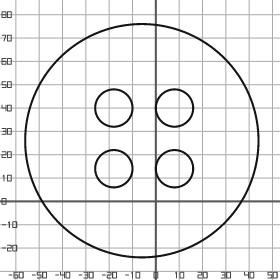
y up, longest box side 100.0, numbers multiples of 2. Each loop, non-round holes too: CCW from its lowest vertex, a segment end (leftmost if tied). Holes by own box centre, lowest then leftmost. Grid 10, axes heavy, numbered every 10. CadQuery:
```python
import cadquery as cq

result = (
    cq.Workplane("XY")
    .moveTo(-6.0, 26.0)
    .circle(50.0)
    .moveTo(-18.0, 14.0)
    .circle(8.0)
    .moveTo(8.0, 14.0)
    .circle(8.0)
    .moveTo(-18.0, 40.0)
    .circle(8.0)
    .moveTo(8.0, 40.0)
    .circle(8.0)
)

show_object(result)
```